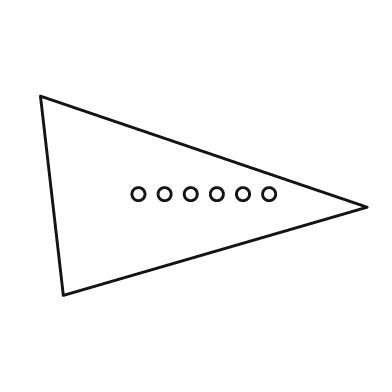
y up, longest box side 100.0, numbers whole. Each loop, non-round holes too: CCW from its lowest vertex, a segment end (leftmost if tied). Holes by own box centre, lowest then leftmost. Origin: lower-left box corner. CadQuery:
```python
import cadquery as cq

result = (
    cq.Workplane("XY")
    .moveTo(7.0, 0.0)
    .lineTo(100.0, 27.0)
    .lineTo(0.0, 61.0)
    .close()
    .moveTo(30.0, 31.0)
    .circle(2.0)
    .moveTo(38.0, 31.0)
    .circle(2.0)
    .moveTo(46.0, 31.0)
    .circle(2.0)
    .moveTo(54.0, 31.0)
    .circle(2.0)
    .moveTo(62.0, 31.0)
    .circle(2.0)
    .moveTo(70.0, 31.0)
    .circle(2.0)
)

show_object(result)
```